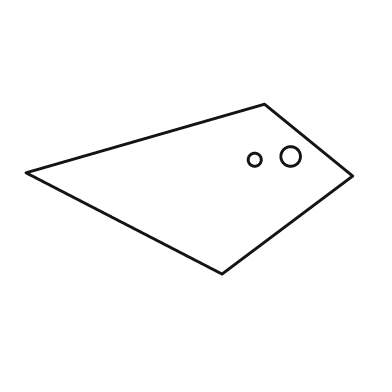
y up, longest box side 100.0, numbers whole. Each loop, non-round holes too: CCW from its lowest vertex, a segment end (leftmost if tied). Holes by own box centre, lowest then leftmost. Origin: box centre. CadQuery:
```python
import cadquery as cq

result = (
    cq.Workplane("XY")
    .moveTo(10.0, -26.0)
    .lineTo(50.0, 4.0)
    .lineTo(23.0, 26.0)
    .lineTo(-50.0, 5.0)
    .close()
    .moveTo(20.0, 9.0)
    .circle(2.0)
    .moveTo(31.0, 10.0)
    .circle(3.0)
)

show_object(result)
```